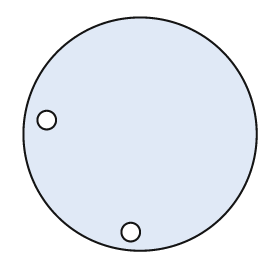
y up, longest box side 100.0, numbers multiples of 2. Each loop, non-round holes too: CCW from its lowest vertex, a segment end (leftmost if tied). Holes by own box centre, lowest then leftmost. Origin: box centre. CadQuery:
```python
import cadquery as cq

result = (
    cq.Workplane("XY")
    .moveTo(0.0, 0.0)
    .circle(50.0)
    .moveTo(-4.0, -42.0)
    .circle(4.0)
    .moveTo(-40.0, 6.0)
    .circle(4.0)
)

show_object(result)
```